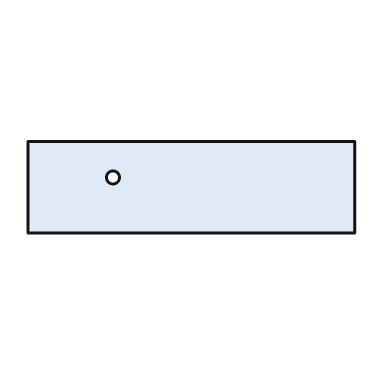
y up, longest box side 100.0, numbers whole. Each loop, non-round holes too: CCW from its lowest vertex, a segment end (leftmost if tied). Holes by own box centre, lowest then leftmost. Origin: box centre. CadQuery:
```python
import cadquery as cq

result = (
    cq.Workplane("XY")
    .moveTo(-50.0, -14.0)
    .lineTo(50.0, -14.0)
    .lineTo(50.0, 14.0)
    .lineTo(-50.0, 14.0)
    .close()
    .moveTo(-24.0, 3.0)
    .circle(2.0)
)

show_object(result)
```